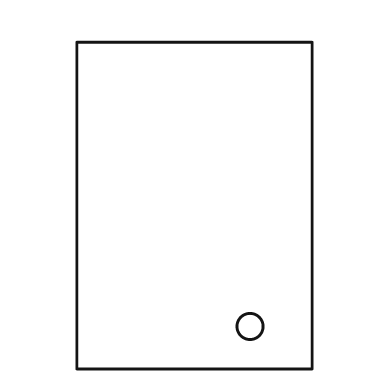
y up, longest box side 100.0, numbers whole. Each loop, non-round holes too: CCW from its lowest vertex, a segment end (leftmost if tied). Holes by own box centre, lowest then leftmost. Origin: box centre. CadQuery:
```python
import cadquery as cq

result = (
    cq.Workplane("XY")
    .moveTo(-36.0, -50.0)
    .lineTo(36.0, -50.0)
    .lineTo(36.0, 50.0)
    .lineTo(-36.0, 50.0)
    .close()
    .moveTo(17.0, -37.0)
    .circle(4.0)
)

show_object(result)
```